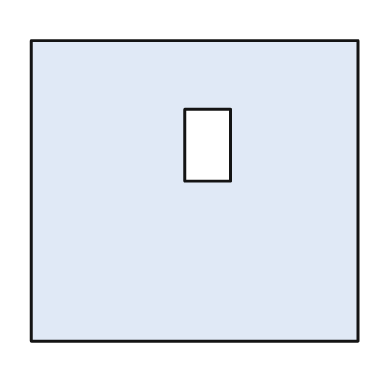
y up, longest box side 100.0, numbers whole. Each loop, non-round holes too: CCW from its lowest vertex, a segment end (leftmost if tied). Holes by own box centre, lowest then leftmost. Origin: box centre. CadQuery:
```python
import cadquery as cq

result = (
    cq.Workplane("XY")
    .moveTo(-50.0, -46.0)
    .lineTo(50.0, -46.0)
    .lineTo(50.0, 46.0)
    .lineTo(-50.0, 46.0)
    .close()
    .moveTo(-3.0, 3.0)
    .lineTo(11.0, 3.0)
    .lineTo(11.0, 25.0)
    .lineTo(-3.0, 25.0)
    .close()
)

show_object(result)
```